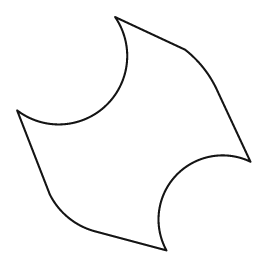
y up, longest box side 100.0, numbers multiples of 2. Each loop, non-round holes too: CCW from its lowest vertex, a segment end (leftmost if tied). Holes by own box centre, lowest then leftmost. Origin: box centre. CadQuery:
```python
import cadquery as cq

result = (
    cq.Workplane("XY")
    .moveTo(14.0, -50.0)
    .threePointArc((18.0, -18.0), (50.0, -12.0))
    .lineTo(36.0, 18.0)
    .threePointArc((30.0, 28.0), (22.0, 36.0))
    .lineTo(-8.0, 50.0)
    .threePointArc((-12.0, 12.0), (-50.0, 10.0))
    .lineTo(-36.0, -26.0)
    .threePointArc((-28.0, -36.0), (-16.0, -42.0))
    .close()
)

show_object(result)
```